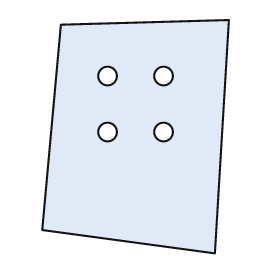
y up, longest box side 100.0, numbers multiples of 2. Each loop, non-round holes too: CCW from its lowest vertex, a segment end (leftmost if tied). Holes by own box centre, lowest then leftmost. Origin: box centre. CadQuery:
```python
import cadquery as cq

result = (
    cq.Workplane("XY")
    .moveTo(34.0, -50.0)
    .lineTo(40.0, 50.0)
    .lineTo(-32.0, 48.0)
    .lineTo(-40.0, -40.0)
    .close()
    .moveTo(-12.0, 2.0)
    .circle(4.0)
    .moveTo(12.0, 2.0)
    .circle(4.0)
    .moveTo(-12.0, 26.0)
    .circle(4.0)
    .moveTo(12.0, 26.0)
    .circle(4.0)
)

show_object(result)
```